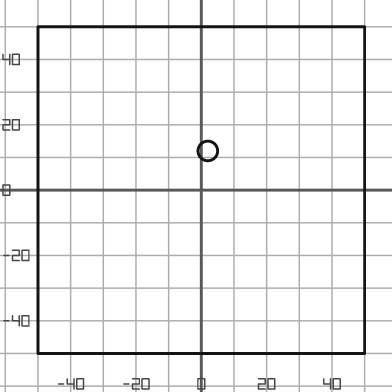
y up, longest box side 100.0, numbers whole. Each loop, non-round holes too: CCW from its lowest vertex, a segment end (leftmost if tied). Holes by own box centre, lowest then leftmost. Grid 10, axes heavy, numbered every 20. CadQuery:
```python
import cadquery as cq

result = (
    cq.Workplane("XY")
    .moveTo(-50.0, -50.0)
    .lineTo(50.0, -50.0)
    .lineTo(50.0, 50.0)
    .lineTo(-50.0, 50.0)
    .close()
    .moveTo(2.0, 12.0)
    .circle(3.0)
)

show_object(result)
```